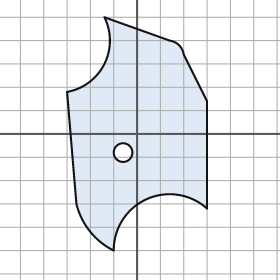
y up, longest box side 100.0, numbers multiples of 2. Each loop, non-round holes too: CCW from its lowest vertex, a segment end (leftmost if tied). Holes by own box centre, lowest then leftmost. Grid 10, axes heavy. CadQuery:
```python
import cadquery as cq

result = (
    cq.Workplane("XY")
    .moveTo(-10.0, -50.0)
    .threePointArc((4.0, -28.0), (30.0, -32.0))
    .lineTo(30.0, 14.0)
    .lineTo(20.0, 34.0)
    .threePointArc((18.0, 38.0), (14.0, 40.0))
    .lineTo(-14.0, 50.0)
    .threePointArc((-14.0, 30.0), (-30.0, 18.0))
    .lineTo(-26.0, -30.0)
    .threePointArc((-20.0, -42.0), (-10.0, -50.0))
    .close()
    .moveTo(-6.0, -8.0)
    .circle(4.0)
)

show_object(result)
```